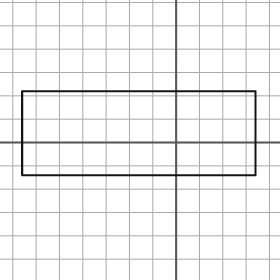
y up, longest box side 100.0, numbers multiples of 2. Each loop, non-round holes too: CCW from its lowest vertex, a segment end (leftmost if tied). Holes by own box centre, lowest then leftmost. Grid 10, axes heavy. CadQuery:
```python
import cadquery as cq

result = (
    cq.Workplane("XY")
    .moveTo(-66.0, -14.0)
    .lineTo(34.0, -14.0)
    .lineTo(34.0, 22.0)
    .lineTo(-66.0, 22.0)
    .close()
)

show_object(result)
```